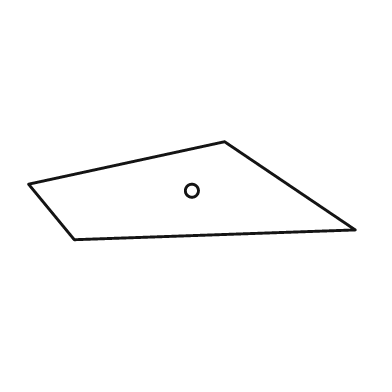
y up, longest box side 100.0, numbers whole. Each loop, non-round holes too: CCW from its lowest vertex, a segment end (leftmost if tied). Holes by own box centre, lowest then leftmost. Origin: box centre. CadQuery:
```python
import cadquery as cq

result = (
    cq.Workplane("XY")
    .moveTo(-36.0, -15.0)
    .lineTo(50.0, -12.0)
    .lineTo(10.0, 15.0)
    .lineTo(-50.0, 2.0)
    .close()
    .moveTo(0.0, 0.0)
    .circle(2.0)
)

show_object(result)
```